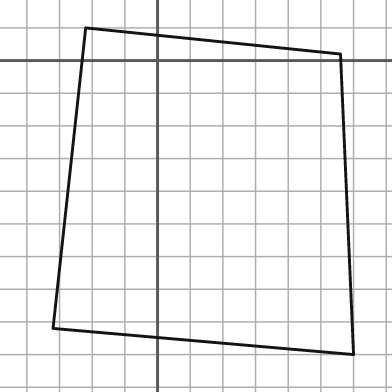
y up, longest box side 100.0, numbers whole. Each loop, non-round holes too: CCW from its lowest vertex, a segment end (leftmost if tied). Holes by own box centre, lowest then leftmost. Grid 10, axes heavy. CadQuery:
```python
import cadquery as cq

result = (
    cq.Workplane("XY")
    .moveTo(60.0, -90.0)
    .lineTo(56.0, 2.0)
    .lineTo(-22.0, 10.0)
    .lineTo(-32.0, -82.0)
    .close()
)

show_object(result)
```